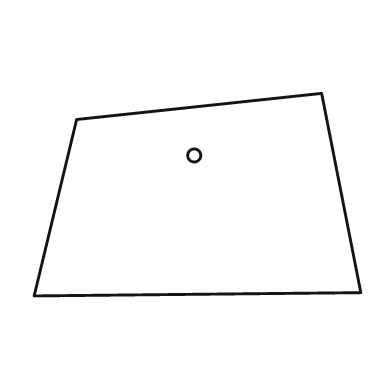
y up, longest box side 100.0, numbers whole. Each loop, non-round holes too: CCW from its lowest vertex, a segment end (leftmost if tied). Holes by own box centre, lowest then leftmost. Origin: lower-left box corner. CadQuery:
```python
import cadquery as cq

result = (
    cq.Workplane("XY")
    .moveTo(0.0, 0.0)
    .lineTo(100.0, 1.0)
    .lineTo(88.0, 62.0)
    .lineTo(13.0, 54.0)
    .close()
    .moveTo(49.0, 43.0)
    .circle(2.0)
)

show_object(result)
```